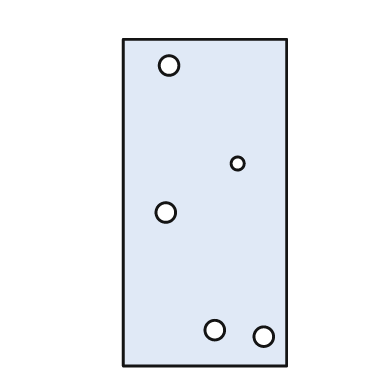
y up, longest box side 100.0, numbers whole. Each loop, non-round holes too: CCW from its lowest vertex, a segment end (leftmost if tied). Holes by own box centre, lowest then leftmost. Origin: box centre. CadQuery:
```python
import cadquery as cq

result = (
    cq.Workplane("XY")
    .moveTo(-25.0, -50.0)
    .lineTo(25.0, -50.0)
    .lineTo(25.0, 50.0)
    .lineTo(-25.0, 50.0)
    .close()
    .moveTo(18.0, -41.0)
    .circle(3.0)
    .moveTo(3.0, -39.0)
    .circle(3.0)
    .moveTo(-12.0, -3.0)
    .circle(3.0)
    .moveTo(10.0, 12.0)
    .circle(2.0)
    .moveTo(-11.0, 42.0)
    .circle(3.0)
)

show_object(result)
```